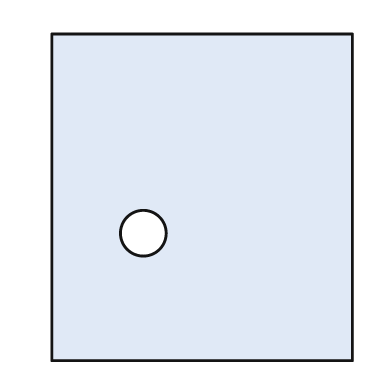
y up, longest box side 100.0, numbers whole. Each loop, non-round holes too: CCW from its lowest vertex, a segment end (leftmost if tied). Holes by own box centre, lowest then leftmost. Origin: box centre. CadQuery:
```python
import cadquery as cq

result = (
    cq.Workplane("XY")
    .moveTo(-46.0, -50.0)
    .lineTo(46.0, -50.0)
    .lineTo(46.0, 50.0)
    .lineTo(-46.0, 50.0)
    .close()
    .moveTo(-18.0, -11.0)
    .circle(7.0)
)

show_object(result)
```